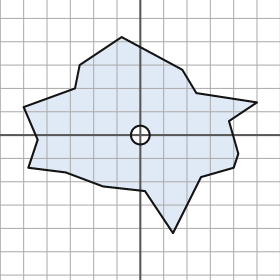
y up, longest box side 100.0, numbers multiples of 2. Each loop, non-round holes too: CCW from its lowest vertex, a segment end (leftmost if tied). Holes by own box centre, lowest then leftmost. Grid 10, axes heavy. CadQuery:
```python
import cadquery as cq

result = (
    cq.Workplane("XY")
    .moveTo(14.0, -42.0)
    .lineTo(26.0, -18.0)
    .lineTo(40.0, -14.0)
    .lineTo(42.0, -8.0)
    .lineTo(38.0, 6.0)
    .lineTo(50.0, 14.0)
    .lineTo(24.0, 18.0)
    .lineTo(18.0, 28.0)
    .lineTo(-8.0, 42.0)
    .lineTo(-26.0, 30.0)
    .lineTo(-28.0, 20.0)
    .lineTo(-50.0, 12.0)
    .lineTo(-44.0, -2.0)
    .lineTo(-48.0, -14.0)
    .lineTo(-32.0, -16.0)
    .lineTo(-16.0, -22.0)
    .lineTo(2.0, -24.0)
    .close()
    .moveTo(0.0, 0.0)
    .circle(4.0)
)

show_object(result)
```